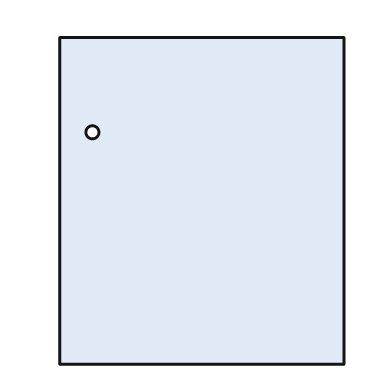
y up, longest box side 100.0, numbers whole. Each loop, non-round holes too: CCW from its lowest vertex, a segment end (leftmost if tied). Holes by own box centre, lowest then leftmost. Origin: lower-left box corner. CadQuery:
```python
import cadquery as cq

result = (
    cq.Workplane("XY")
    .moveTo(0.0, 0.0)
    .lineTo(87.0, 0.0)
    .lineTo(87.0, 100.0)
    .lineTo(0.0, 100.0)
    .close()
    .moveTo(10.0, 71.0)
    .circle(2.0)
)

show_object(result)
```